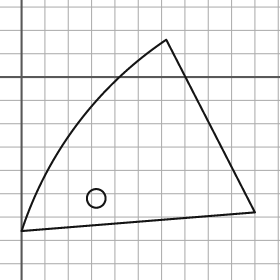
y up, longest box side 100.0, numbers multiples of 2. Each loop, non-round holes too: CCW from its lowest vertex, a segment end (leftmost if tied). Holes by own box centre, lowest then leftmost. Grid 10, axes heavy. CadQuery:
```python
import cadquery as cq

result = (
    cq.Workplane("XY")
    .moveTo(0.0, -66.0)
    .lineTo(100.0, -58.0)
    .lineTo(62.0, 16.0)
    .threePointArc((24.0, -20.0), (0.0, -66.0))
    .close()
    .moveTo(32.0, -52.0)
    .circle(4.0)
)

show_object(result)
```